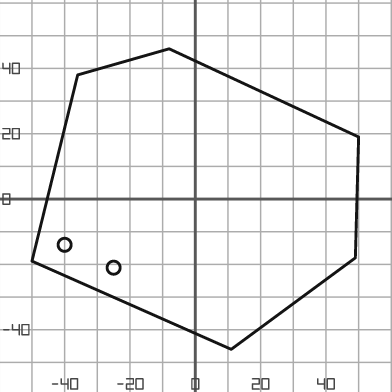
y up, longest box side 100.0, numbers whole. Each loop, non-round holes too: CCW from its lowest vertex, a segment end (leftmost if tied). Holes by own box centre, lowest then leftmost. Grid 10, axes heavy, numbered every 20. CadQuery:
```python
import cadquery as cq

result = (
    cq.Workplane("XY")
    .moveTo(11.0, -46.0)
    .lineTo(49.0, -18.0)
    .lineTo(50.0, 19.0)
    .lineTo(-8.0, 46.0)
    .lineTo(-36.0, 38.0)
    .lineTo(-50.0, -19.0)
    .close()
    .moveTo(-25.0, -21.0)
    .circle(2.0)
    .moveTo(-40.0, -14.0)
    .circle(2.0)
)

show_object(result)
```